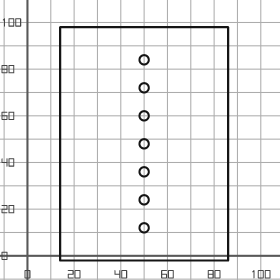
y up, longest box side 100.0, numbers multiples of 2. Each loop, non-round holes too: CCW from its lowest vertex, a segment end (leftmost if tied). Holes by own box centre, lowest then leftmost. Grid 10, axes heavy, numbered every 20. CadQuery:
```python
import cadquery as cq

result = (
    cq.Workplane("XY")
    .moveTo(14.0, -2.0)
    .lineTo(86.0, -2.0)
    .lineTo(86.0, 98.0)
    .lineTo(14.0, 98.0)
    .close()
    .moveTo(50.0, 12.0)
    .circle(2.0)
    .moveTo(50.0, 24.0)
    .circle(2.0)
    .moveTo(50.0, 36.0)
    .circle(2.0)
    .moveTo(50.0, 48.0)
    .circle(2.0)
    .moveTo(50.0, 60.0)
    .circle(2.0)
    .moveTo(50.0, 72.0)
    .circle(2.0)
    .moveTo(50.0, 84.0)
    .circle(2.0)
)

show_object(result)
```